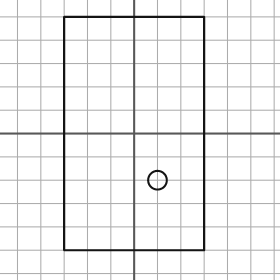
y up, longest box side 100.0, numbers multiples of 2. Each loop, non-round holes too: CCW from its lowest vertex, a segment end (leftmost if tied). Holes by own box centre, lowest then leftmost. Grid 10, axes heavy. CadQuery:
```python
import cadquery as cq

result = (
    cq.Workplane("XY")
    .moveTo(-30.0, -50.0)
    .lineTo(30.0, -50.0)
    .lineTo(30.0, 50.0)
    .lineTo(-30.0, 50.0)
    .close()
    .moveTo(10.0, -20.0)
    .circle(4.0)
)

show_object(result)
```